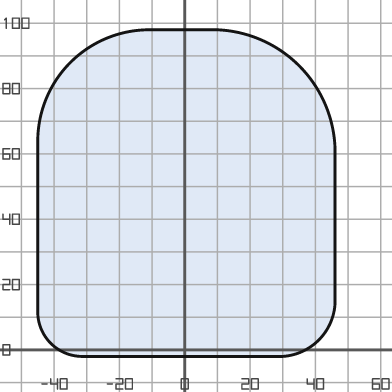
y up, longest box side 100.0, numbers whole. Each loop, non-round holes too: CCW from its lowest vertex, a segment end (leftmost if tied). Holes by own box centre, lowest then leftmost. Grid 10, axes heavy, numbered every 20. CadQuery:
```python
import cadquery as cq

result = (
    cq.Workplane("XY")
    .moveTo(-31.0, -2.0)
    .lineTo(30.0, -2.0)
    .threePointArc((41.0, 3.0), (46.0, 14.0))
    .lineTo(46.0, 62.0)
    .threePointArc((35.0, 87.0), (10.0, 98.0))
    .lineTo(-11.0, 98.0)
    .threePointArc((-35.0, 88.0), (-45.0, 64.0))
    .lineTo(-45.0, 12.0)
    .threePointArc((-41.0, 2.0), (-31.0, -2.0))
    .close()
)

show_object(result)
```